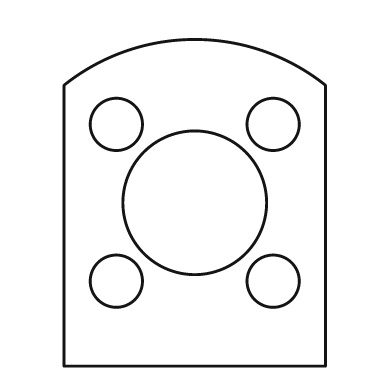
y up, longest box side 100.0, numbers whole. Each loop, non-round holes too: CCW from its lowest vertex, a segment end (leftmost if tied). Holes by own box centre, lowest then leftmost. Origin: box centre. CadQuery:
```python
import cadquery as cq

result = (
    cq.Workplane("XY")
    .moveTo(-40.0, -50.0)
    .lineTo(40.0, -50.0)
    .lineTo(40.0, 36.0)
    .threePointArc((0.0, 50.0), (-40.0, 36.0))
    .close()
    .moveTo(-24.0, -24.0)
    .circle(8.0)
    .moveTo(24.0, -24.0)
    .circle(8.0)
    .moveTo(0.0, 0.0)
    .circle(22.0)
    .moveTo(-24.0, 24.0)
    .circle(8.0)
    .moveTo(24.0, 24.0)
    .circle(8.0)
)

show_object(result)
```